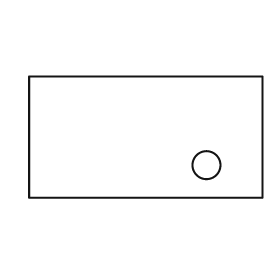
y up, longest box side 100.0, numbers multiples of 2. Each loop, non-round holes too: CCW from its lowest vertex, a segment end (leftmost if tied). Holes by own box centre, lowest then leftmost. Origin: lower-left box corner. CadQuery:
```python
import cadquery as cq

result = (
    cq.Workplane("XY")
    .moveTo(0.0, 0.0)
    .lineTo(100.0, 0.0)
    .lineTo(100.0, 52.0)
    .lineTo(0.0, 52.0)
    .close()
    .moveTo(76.0, 14.0)
    .circle(6.0)
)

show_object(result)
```